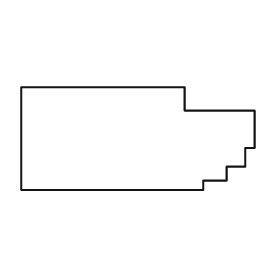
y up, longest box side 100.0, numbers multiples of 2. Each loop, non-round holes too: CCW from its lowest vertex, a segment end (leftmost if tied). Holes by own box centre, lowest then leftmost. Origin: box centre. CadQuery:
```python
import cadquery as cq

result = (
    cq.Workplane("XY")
    .moveTo(-50.0, -22.0)
    .lineTo(28.0, -22.0)
    .lineTo(28.0, -18.0)
    .lineTo(38.0, -18.0)
    .lineTo(38.0, -12.0)
    .lineTo(46.0, -12.0)
    .lineTo(46.0, -4.0)
    .lineTo(50.0, -4.0)
    .lineTo(50.0, 12.0)
    .lineTo(20.0, 12.0)
    .lineTo(20.0, 22.0)
    .lineTo(-50.0, 22.0)
    .close()
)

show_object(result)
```